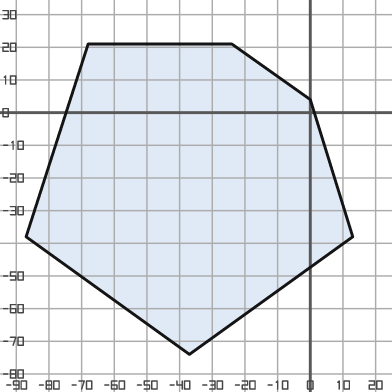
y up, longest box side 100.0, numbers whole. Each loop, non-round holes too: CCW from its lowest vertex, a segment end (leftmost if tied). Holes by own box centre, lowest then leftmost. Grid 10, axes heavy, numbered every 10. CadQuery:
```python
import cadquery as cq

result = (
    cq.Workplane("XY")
    .moveTo(-37.0, -74.0)
    .lineTo(13.0, -38.0)
    .lineTo(0.0, 4.0)
    .lineTo(-24.0, 21.0)
    .lineTo(-68.0, 21.0)
    .lineTo(-87.0, -38.0)
    .close()
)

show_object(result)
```